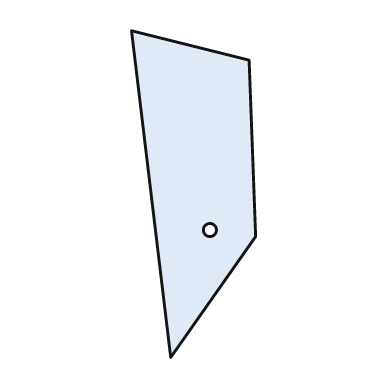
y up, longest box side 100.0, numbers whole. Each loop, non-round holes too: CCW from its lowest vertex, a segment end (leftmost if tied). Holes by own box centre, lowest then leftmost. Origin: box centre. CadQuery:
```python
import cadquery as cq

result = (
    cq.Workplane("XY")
    .moveTo(-7.0, -50.0)
    .lineTo(19.0, -13.0)
    .lineTo(17.0, 41.0)
    .lineTo(-19.0, 50.0)
    .close()
    .moveTo(5.0, -11.0)
    .circle(2.0)
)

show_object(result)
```